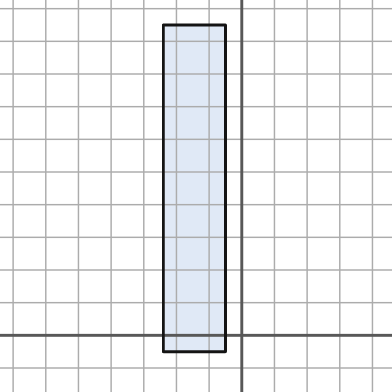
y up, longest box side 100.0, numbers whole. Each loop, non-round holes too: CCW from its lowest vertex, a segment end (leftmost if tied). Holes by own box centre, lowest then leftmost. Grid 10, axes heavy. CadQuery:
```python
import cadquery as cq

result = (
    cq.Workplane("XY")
    .moveTo(-24.0, -5.0)
    .lineTo(-5.0, -5.0)
    .lineTo(-5.0, 95.0)
    .lineTo(-24.0, 95.0)
    .close()
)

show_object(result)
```